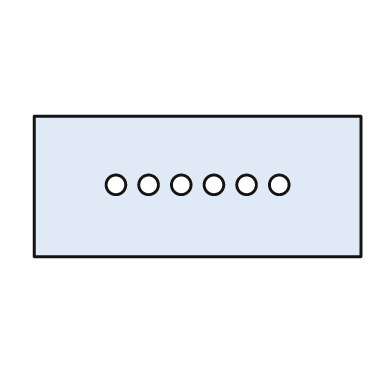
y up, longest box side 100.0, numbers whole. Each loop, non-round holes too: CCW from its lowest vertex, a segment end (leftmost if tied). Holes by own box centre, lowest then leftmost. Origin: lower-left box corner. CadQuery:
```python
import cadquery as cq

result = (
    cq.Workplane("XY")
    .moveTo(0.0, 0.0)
    .lineTo(100.0, 0.0)
    .lineTo(100.0, 43.0)
    .lineTo(0.0, 43.0)
    .close()
    .moveTo(25.0, 22.0)
    .circle(3.0)
    .moveTo(35.0, 22.0)
    .circle(3.0)
    .moveTo(45.0, 22.0)
    .circle(3.0)
    .moveTo(55.0, 22.0)
    .circle(3.0)
    .moveTo(65.0, 22.0)
    .circle(3.0)
    .moveTo(75.0, 22.0)
    .circle(3.0)
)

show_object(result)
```